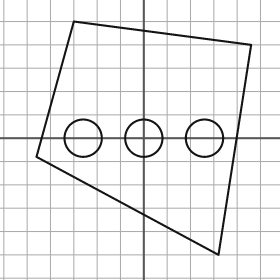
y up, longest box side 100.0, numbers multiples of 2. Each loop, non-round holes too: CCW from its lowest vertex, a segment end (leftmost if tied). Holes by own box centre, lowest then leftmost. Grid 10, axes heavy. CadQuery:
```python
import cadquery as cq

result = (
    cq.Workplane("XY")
    .moveTo(32.0, -50.0)
    .lineTo(46.0, 40.0)
    .lineTo(-30.0, 50.0)
    .lineTo(-46.0, -8.0)
    .close()
    .moveTo(-26.0, 0.0)
    .circle(8.0)
    .moveTo(0.0, 0.0)
    .circle(8.0)
    .moveTo(26.0, 0.0)
    .circle(8.0)
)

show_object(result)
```